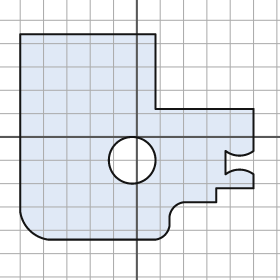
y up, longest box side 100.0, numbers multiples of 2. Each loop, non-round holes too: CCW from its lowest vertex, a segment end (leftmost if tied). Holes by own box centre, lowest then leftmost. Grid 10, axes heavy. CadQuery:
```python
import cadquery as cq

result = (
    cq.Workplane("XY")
    .moveTo(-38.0, -44.0)
    .lineTo(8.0, -44.0)
    .threePointArc((12.0, -42.0), (14.0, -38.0))
    .lineTo(14.0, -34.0)
    .threePointArc((16.0, -30.0), (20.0, -28.0))
    .lineTo(34.0, -28.0)
    .lineTo(34.0, -22.0)
    .lineTo(50.0, -22.0)
    .lineTo(50.0, -16.0)
    .threePointArc((44.0, -14.0), (38.0, -16.0))
    .lineTo(38.0, -6.0)
    .threePointArc((44.0, -8.0), (50.0, -6.0))
    .lineTo(50.0, 12.0)
    .lineTo(8.0, 12.0)
    .lineTo(8.0, 44.0)
    .lineTo(-50.0, 44.0)
    .lineTo(-50.0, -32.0)
    .threePointArc((-46.0, -40.0), (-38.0, -44.0))
    .close()
    .moveTo(-2.0, -10.0)
    .circle(10.0)
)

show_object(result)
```